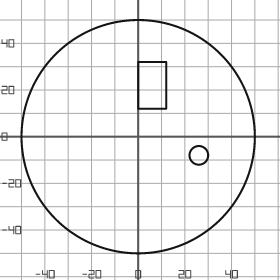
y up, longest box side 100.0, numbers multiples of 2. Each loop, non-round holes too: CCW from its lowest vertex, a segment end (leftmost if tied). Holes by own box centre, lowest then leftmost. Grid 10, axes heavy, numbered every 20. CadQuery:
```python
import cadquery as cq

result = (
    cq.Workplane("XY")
    .moveTo(0.0, 0.0)
    .circle(50.0)
    .moveTo(26.0, -8.0)
    .circle(4.0)
    .moveTo(0.0, 12.0)
    .lineTo(12.0, 12.0)
    .lineTo(12.0, 32.0)
    .lineTo(0.0, 32.0)
    .close()
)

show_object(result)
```